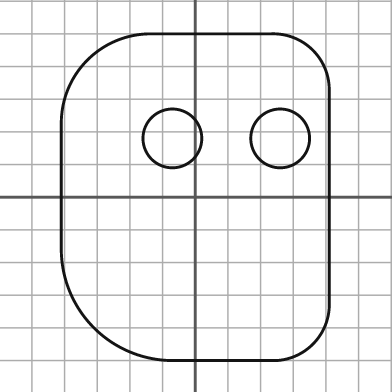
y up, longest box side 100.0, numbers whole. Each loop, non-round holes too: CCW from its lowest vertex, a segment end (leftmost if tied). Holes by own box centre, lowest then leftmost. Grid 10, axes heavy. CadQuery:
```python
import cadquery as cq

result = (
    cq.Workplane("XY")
    .moveTo(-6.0, -50.0)
    .lineTo(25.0, -50.0)
    .threePointArc((36.0, -45.0), (41.0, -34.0))
    .lineTo(41.0, 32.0)
    .threePointArc((36.0, 45.0), (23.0, 50.0))
    .lineTo(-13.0, 50.0)
    .threePointArc((-33.0, 42.0), (-41.0, 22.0))
    .lineTo(-41.0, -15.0)
    .threePointArc((-31.0, -40.0), (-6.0, -50.0))
    .close()
    .moveTo(-7.0, 18.0)
    .circle(9.0)
    .moveTo(26.0, 18.0)
    .circle(9.0)
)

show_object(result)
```